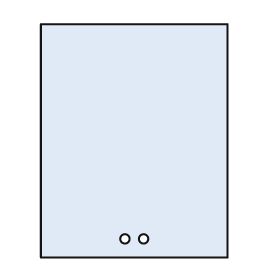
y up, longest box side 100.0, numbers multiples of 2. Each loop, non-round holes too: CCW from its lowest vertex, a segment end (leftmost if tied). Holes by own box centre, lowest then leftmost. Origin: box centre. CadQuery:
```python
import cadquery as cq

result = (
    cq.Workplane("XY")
    .moveTo(-40.0, -50.0)
    .lineTo(40.0, -50.0)
    .lineTo(40.0, 50.0)
    .lineTo(-40.0, 50.0)
    .close()
    .moveTo(-4.0, -42.0)
    .circle(2.0)
    .moveTo(4.0, -42.0)
    .circle(2.0)
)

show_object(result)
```